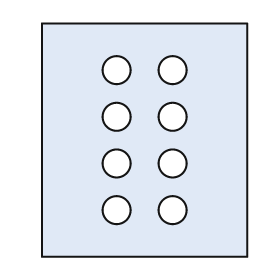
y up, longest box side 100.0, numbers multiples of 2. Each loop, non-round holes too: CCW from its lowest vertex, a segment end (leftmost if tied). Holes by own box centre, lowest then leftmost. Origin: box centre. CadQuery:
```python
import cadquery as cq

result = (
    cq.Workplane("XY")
    .moveTo(-44.0, -50.0)
    .lineTo(44.0, -50.0)
    .lineTo(44.0, 50.0)
    .lineTo(-44.0, 50.0)
    .close()
    .moveTo(-12.0, -30.0)
    .circle(6.0)
    .moveTo(12.0, -30.0)
    .circle(6.0)
    .moveTo(-12.0, -10.0)
    .circle(6.0)
    .moveTo(12.0, -10.0)
    .circle(6.0)
    .moveTo(-12.0, 10.0)
    .circle(6.0)
    .moveTo(12.0, 10.0)
    .circle(6.0)
    .moveTo(-12.0, 30.0)
    .circle(6.0)
    .moveTo(12.0, 30.0)
    .circle(6.0)
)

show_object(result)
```